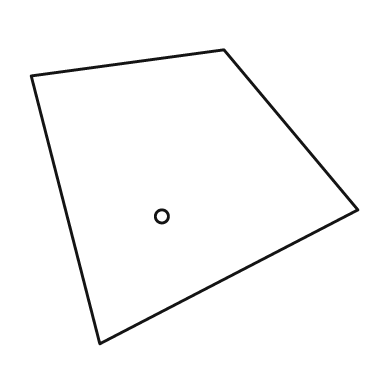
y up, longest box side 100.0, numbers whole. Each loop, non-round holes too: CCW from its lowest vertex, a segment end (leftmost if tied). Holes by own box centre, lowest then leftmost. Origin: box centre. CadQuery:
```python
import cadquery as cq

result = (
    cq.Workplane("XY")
    .moveTo(-29.0, -45.0)
    .lineTo(50.0, -4.0)
    .lineTo(9.0, 45.0)
    .lineTo(-50.0, 37.0)
    .close()
    .moveTo(-10.0, -6.0)
    .circle(2.0)
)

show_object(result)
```